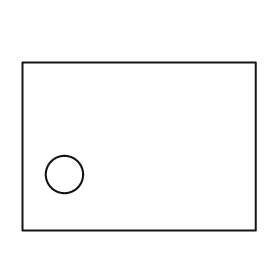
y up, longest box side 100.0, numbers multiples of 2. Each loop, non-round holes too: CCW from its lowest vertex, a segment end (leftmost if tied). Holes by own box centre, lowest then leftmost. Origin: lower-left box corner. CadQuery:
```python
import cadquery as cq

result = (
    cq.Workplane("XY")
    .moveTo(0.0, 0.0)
    .lineTo(100.0, 0.0)
    .lineTo(100.0, 72.0)
    .lineTo(0.0, 72.0)
    .close()
    .moveTo(18.0, 24.0)
    .circle(8.0)
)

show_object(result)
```